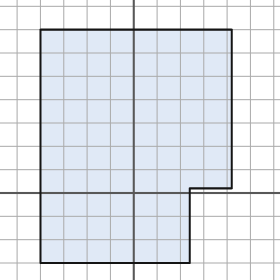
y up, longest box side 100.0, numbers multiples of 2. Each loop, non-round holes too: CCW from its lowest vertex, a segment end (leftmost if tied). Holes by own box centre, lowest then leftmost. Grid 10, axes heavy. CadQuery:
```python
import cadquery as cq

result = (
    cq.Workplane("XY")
    .moveTo(-40.0, -30.0)
    .lineTo(24.0, -30.0)
    .lineTo(24.0, 2.0)
    .lineTo(42.0, 2.0)
    .lineTo(42.0, 70.0)
    .lineTo(-40.0, 70.0)
    .close()
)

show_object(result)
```